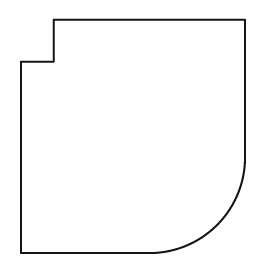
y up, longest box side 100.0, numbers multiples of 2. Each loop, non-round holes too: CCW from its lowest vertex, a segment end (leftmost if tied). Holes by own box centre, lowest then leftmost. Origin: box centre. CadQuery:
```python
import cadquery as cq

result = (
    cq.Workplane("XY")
    .moveTo(-48.0, -50.0)
    .lineTo(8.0, -50.0)
    .threePointArc((36.0, -38.0), (48.0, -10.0))
    .lineTo(48.0, 50.0)
    .lineTo(-34.0, 50.0)
    .lineTo(-34.0, 32.0)
    .lineTo(-48.0, 32.0)
    .close()
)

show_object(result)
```